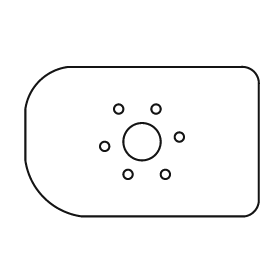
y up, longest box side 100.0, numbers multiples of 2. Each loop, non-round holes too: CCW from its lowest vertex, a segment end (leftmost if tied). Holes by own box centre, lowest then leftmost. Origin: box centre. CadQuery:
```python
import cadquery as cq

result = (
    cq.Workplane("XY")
    .moveTo(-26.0, -32.0)
    .lineTo(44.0, -32.0)
    .threePointArc((48.0, -30.0), (50.0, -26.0))
    .lineTo(50.0, 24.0)
    .threePointArc((48.0, 30.0), (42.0, 32.0))
    .lineTo(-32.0, 32.0)
    .threePointArc((-44.0, 26.0), (-50.0, 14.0))
    .lineTo(-50.0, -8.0)
    .threePointArc((-42.0, -24.0), (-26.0, -32.0))
    .close()
    .moveTo(-6.0, -14.0)
    .circle(2.0)
    .moveTo(10.0, -14.0)
    .circle(2.0)
    .moveTo(-16.0, -2.0)
    .circle(2.0)
    .moveTo(0.0, 0.0)
    .circle(8.0)
    .moveTo(16.0, 2.0)
    .circle(2.0)
    .moveTo(-10.0, 14.0)
    .circle(2.0)
    .moveTo(6.0, 14.0)
    .circle(2.0)
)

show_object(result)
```